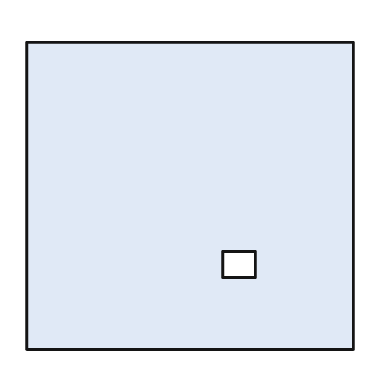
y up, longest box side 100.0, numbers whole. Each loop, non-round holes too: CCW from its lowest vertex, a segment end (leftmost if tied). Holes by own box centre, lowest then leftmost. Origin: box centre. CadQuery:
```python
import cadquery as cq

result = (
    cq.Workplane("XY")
    .moveTo(-50.0, -47.0)
    .lineTo(50.0, -47.0)
    .lineTo(50.0, 47.0)
    .lineTo(-50.0, 47.0)
    .close()
    .moveTo(10.0, -25.0)
    .lineTo(20.0, -25.0)
    .lineTo(20.0, -17.0)
    .lineTo(10.0, -17.0)
    .close()
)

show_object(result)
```